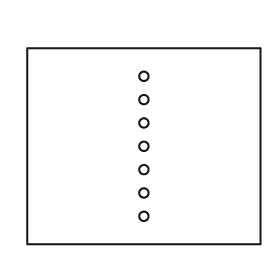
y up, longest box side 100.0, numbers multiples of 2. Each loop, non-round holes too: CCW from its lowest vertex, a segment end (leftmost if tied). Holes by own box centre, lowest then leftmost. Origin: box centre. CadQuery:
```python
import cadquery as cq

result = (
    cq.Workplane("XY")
    .moveTo(-50.0, -42.0)
    .lineTo(50.0, -42.0)
    .lineTo(50.0, 42.0)
    .lineTo(-50.0, 42.0)
    .close()
    .moveTo(0.0, -30.0)
    .circle(2.0)
    .moveTo(0.0, -20.0)
    .circle(2.0)
    .moveTo(0.0, -10.0)
    .circle(2.0)
    .moveTo(0.0, 0.0)
    .circle(2.0)
    .moveTo(0.0, 10.0)
    .circle(2.0)
    .moveTo(0.0, 20.0)
    .circle(2.0)
    .moveTo(0.0, 30.0)
    .circle(2.0)
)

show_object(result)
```